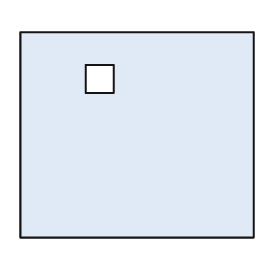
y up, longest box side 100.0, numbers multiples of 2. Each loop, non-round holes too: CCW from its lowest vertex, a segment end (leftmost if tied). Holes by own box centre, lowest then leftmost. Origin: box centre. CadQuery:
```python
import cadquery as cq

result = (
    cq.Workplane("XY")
    .moveTo(-50.0, -44.0)
    .lineTo(50.0, -44.0)
    .lineTo(50.0, 44.0)
    .lineTo(-50.0, 44.0)
    .close()
    .moveTo(-22.0, 18.0)
    .lineTo(-10.0, 18.0)
    .lineTo(-10.0, 30.0)
    .lineTo(-22.0, 30.0)
    .close()
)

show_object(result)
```